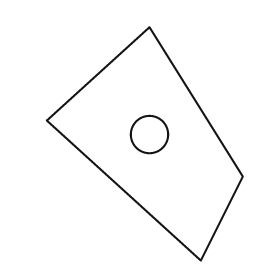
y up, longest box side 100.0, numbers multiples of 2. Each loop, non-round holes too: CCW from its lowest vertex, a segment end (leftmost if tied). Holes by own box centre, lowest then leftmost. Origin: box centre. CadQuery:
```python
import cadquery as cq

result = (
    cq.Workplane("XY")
    .moveTo(24.0, -50.0)
    .lineTo(42.0, -14.0)
    .lineTo(2.0, 50.0)
    .lineTo(-42.0, 10.0)
    .close()
    .moveTo(2.0, 4.0)
    .circle(8.0)
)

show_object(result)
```